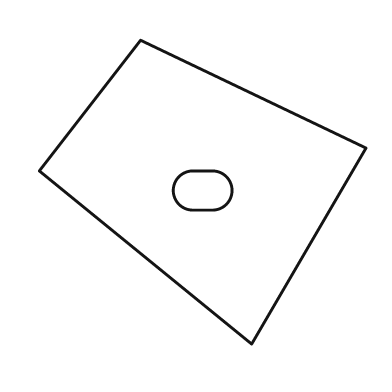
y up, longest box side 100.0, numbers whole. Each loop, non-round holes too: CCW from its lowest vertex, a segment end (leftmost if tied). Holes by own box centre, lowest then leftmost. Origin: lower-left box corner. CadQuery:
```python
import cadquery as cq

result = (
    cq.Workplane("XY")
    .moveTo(65.0, 0.0)
    .lineTo(100.0, 60.0)
    .lineTo(31.0, 93.0)
    .lineTo(0.0, 53.0)
    .close()
    .moveTo(47.0, 41.0)
    .lineTo(53.0, 41.0)
    .threePointArc((59.0, 47.0), (53.0, 53.0))
    .lineTo(47.0, 53.0)
    .threePointArc((41.0, 47.0), (47.0, 41.0))
    .close()
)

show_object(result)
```